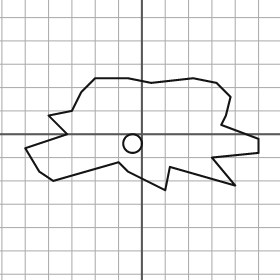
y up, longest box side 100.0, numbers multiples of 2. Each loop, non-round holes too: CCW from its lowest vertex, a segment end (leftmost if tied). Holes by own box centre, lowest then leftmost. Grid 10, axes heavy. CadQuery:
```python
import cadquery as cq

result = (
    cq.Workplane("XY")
    .moveTo(10.0, -24.0)
    .lineTo(12.0, -14.0)
    .lineTo(40.0, -22.0)
    .lineTo(30.0, -10.0)
    .lineTo(50.0, -8.0)
    .lineTo(50.0, -2.0)
    .lineTo(34.0, 4.0)
    .lineTo(36.0, 8.0)
    .lineTo(38.0, 16.0)
    .lineTo(32.0, 22.0)
    .lineTo(22.0, 24.0)
    .lineTo(4.0, 22.0)
    .lineTo(-6.0, 24.0)
    .lineTo(-20.0, 24.0)
    .lineTo(-26.0, 18.0)
    .lineTo(-30.0, 10.0)
    .lineTo(-40.0, 8.0)
    .lineTo(-32.0, 0.0)
    .lineTo(-50.0, -6.0)
    .lineTo(-44.0, -16.0)
    .lineTo(-38.0, -20.0)
    .lineTo(-10.0, -12.0)
    .lineTo(-6.0, -16.0)
    .close()
    .moveTo(-4.0, -4.0)
    .circle(4.0)
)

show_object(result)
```